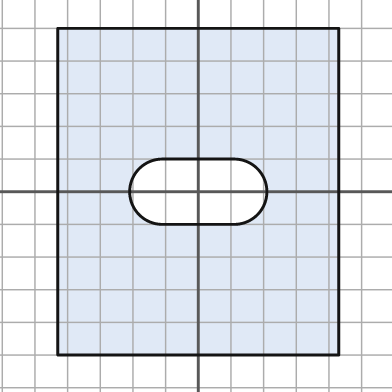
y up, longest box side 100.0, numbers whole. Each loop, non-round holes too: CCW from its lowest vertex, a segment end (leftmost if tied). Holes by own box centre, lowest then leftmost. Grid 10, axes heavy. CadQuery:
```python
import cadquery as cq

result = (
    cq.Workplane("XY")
    .moveTo(-43.0, -50.0)
    .lineTo(43.0, -50.0)
    .lineTo(43.0, 50.0)
    .lineTo(-43.0, 50.0)
    .close()
    .moveTo(-11.0, -10.0)
    .lineTo(11.0, -10.0)
    .threePointArc((21.0, 0.0), (11.0, 10.0))
    .lineTo(-11.0, 10.0)
    .threePointArc((-21.0, 0.0), (-11.0, -10.0))
    .close()
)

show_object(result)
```